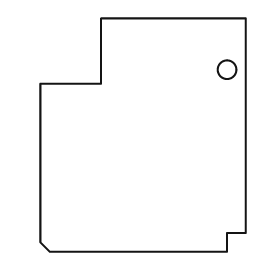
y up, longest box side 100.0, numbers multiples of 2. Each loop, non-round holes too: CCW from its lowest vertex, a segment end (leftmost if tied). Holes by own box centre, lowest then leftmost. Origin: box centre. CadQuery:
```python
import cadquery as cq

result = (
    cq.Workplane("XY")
    .moveTo(-40.0, -50.0)
    .lineTo(36.0, -50.0)
    .lineTo(36.0, -42.0)
    .lineTo(44.0, -42.0)
    .lineTo(44.0, 50.0)
    .lineTo(-18.0, 50.0)
    .lineTo(-18.0, 22.0)
    .lineTo(-44.0, 22.0)
    .lineTo(-44.0, -46.0)
    .close()
    .moveTo(36.0, 28.0)
    .circle(4.0)
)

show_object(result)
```